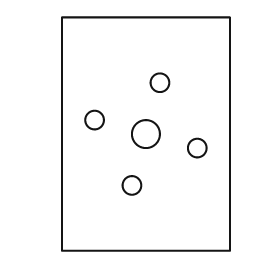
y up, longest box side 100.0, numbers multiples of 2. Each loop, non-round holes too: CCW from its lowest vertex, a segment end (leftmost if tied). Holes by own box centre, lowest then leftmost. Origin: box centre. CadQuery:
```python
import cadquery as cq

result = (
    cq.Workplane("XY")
    .moveTo(-36.0, -50.0)
    .lineTo(36.0, -50.0)
    .lineTo(36.0, 50.0)
    .lineTo(-36.0, 50.0)
    .close()
    .moveTo(-6.0, -22.0)
    .circle(4.0)
    .moveTo(22.0, -6.0)
    .circle(4.0)
    .moveTo(0.0, 0.0)
    .circle(6.0)
    .moveTo(-22.0, 6.0)
    .circle(4.0)
    .moveTo(6.0, 22.0)
    .circle(4.0)
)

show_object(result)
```